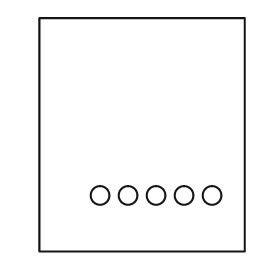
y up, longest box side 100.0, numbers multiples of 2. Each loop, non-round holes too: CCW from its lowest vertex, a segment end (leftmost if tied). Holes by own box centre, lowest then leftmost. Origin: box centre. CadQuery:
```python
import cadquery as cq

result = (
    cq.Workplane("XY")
    .moveTo(-44.0, -50.0)
    .lineTo(44.0, -50.0)
    .lineTo(44.0, 50.0)
    .lineTo(-44.0, 50.0)
    .close()
    .moveTo(-18.0, -26.0)
    .circle(4.0)
    .moveTo(-6.0, -26.0)
    .circle(4.0)
    .moveTo(6.0, -26.0)
    .circle(4.0)
    .moveTo(18.0, -26.0)
    .circle(4.0)
    .moveTo(30.0, -26.0)
    .circle(4.0)
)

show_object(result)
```